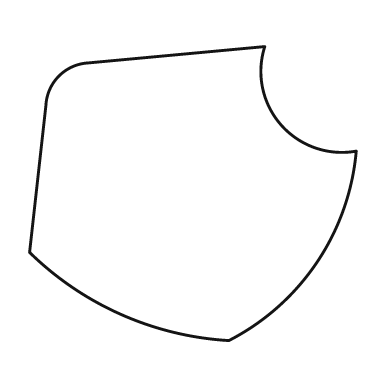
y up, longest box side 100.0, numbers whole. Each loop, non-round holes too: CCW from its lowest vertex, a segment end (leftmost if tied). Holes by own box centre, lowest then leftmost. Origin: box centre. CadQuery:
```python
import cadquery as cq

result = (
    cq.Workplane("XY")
    .moveTo(11.0, -45.0)
    .threePointArc((38.0, -21.0), (50.0, 13.0))
    .threePointArc((27.0, 21.0), (22.0, 45.0))
    .lineTo(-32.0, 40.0)
    .threePointArc((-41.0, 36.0), (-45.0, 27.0))
    .lineTo(-50.0, -18.0)
    .threePointArc((-22.0, -37.0), (11.0, -45.0))
    .close()
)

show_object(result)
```